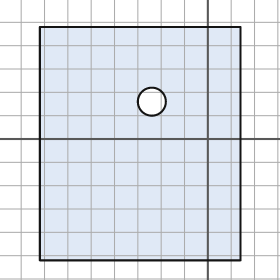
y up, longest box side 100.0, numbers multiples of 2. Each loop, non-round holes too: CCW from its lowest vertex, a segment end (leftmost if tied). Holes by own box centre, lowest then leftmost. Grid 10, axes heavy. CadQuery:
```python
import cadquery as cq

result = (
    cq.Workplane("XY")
    .moveTo(-72.0, -52.0)
    .lineTo(14.0, -52.0)
    .lineTo(14.0, 48.0)
    .lineTo(-72.0, 48.0)
    .close()
    .moveTo(-24.0, 16.0)
    .circle(6.0)
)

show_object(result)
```